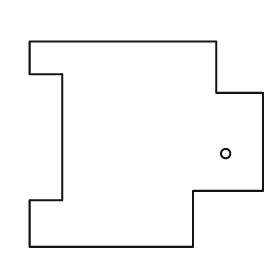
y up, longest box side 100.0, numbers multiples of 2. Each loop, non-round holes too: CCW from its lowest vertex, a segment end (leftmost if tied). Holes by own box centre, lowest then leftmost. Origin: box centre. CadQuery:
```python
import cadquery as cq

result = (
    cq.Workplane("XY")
    .moveTo(-50.0, -44.0)
    .lineTo(20.0, -44.0)
    .lineTo(20.0, -20.0)
    .lineTo(50.0, -20.0)
    .lineTo(50.0, 22.0)
    .lineTo(30.0, 22.0)
    .lineTo(30.0, 44.0)
    .lineTo(-50.0, 44.0)
    .lineTo(-50.0, 30.0)
    .lineTo(-36.0, 30.0)
    .lineTo(-36.0, -24.0)
    .lineTo(-50.0, -24.0)
    .close()
    .moveTo(34.0, -4.0)
    .circle(2.0)
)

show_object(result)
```